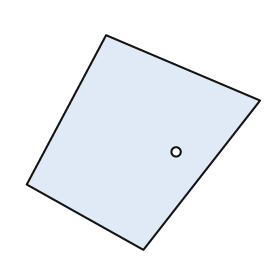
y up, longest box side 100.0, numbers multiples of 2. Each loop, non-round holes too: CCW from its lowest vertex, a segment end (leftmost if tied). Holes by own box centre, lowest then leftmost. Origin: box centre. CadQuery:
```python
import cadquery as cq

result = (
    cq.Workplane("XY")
    .moveTo(0.0, -46.0)
    .lineTo(50.0, 18.0)
    .lineTo(-16.0, 46.0)
    .lineTo(-50.0, -18.0)
    .close()
    .moveTo(14.0, -4.0)
    .circle(2.0)
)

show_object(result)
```